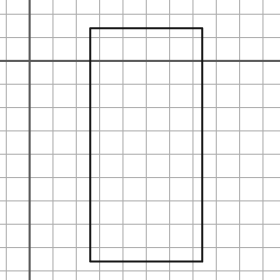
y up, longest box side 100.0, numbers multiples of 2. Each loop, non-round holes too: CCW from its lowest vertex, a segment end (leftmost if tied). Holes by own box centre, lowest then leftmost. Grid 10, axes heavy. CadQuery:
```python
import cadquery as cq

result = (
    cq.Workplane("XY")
    .moveTo(26.0, -86.0)
    .lineTo(74.0, -86.0)
    .lineTo(74.0, 14.0)
    .lineTo(26.0, 14.0)
    .close()
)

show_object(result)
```